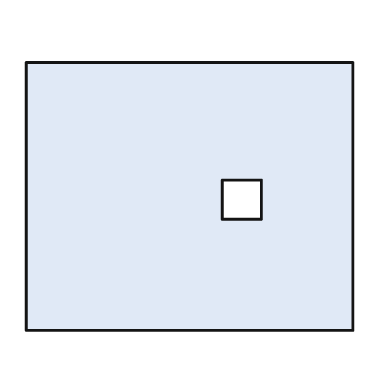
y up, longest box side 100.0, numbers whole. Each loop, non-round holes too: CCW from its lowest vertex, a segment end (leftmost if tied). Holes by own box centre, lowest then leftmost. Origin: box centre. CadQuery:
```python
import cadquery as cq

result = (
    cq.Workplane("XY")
    .moveTo(-50.0, -41.0)
    .lineTo(50.0, -41.0)
    .lineTo(50.0, 41.0)
    .lineTo(-50.0, 41.0)
    .close()
    .moveTo(10.0, -7.0)
    .lineTo(22.0, -7.0)
    .lineTo(22.0, 5.0)
    .lineTo(10.0, 5.0)
    .close()
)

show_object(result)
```